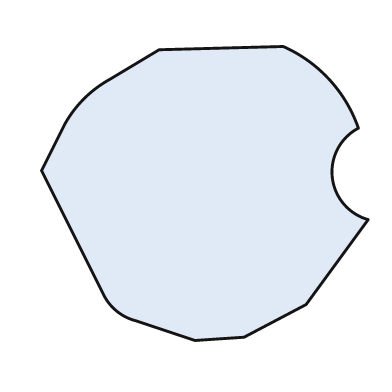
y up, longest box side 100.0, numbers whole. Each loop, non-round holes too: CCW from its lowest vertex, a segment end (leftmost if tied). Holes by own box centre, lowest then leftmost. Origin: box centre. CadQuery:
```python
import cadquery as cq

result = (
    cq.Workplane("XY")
    .moveTo(-3.0, -45.0)
    .lineTo(12.0, -44.0)
    .lineTo(31.0, -34.0)
    .lineTo(50.0, -8.0)
    .threePointArc((39.0, 5.0), (47.0, 20.0))
    .threePointArc((38.0, 35.0), (24.0, 45.0))
    .lineTo(-14.0, 44.0)
    .lineTo(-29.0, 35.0)
    .threePointArc((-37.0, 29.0), (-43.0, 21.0))
    .lineTo(-50.0, 7.0)
    .lineTo(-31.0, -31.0)
    .threePointArc((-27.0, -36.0), (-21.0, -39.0))
    .close()
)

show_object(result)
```